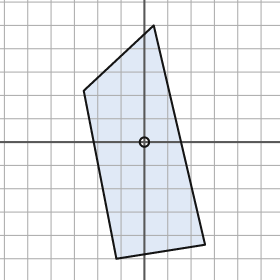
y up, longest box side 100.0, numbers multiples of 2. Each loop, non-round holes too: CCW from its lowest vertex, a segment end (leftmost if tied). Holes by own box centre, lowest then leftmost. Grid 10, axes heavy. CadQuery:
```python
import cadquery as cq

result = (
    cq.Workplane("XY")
    .moveTo(-12.0, -50.0)
    .lineTo(26.0, -44.0)
    .lineTo(4.0, 50.0)
    .lineTo(-26.0, 22.0)
    .close()
    .moveTo(0.0, 0.0)
    .circle(2.0)
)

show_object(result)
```